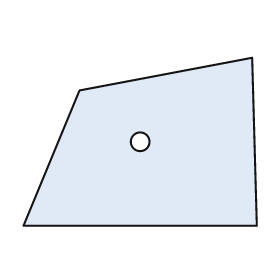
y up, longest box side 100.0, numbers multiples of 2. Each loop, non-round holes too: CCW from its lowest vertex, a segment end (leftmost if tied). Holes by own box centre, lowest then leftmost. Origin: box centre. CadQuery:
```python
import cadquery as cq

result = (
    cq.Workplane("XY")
    .moveTo(-50.0, -36.0)
    .lineTo(50.0, -36.0)
    .lineTo(48.0, 36.0)
    .lineTo(-26.0, 22.0)
    .close()
    .moveTo(0.0, 0.0)
    .circle(4.0)
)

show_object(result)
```